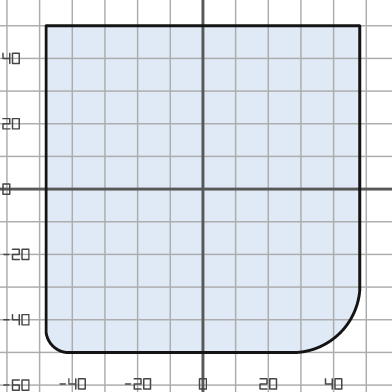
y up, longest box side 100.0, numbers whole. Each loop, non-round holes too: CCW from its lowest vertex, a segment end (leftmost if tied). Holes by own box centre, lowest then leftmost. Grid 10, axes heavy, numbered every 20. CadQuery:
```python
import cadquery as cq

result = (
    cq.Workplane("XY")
    .moveTo(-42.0, -50.0)
    .lineTo(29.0, -50.0)
    .threePointArc((42.0, -44.0), (48.0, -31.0))
    .lineTo(48.0, 50.0)
    .lineTo(-48.0, 50.0)
    .lineTo(-48.0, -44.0)
    .threePointArc((-46.0, -48.0), (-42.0, -50.0))
    .close()
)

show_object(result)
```